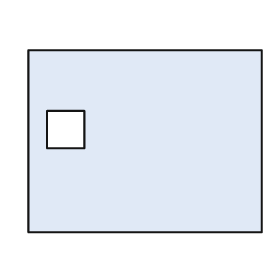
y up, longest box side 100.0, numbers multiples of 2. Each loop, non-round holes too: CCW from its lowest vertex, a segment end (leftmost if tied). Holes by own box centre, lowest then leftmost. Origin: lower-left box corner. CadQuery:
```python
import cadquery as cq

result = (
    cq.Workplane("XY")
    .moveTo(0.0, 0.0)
    .lineTo(100.0, 0.0)
    .lineTo(100.0, 78.0)
    .lineTo(0.0, 78.0)
    .close()
    .moveTo(8.0, 36.0)
    .lineTo(24.0, 36.0)
    .lineTo(24.0, 52.0)
    .lineTo(8.0, 52.0)
    .close()
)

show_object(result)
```